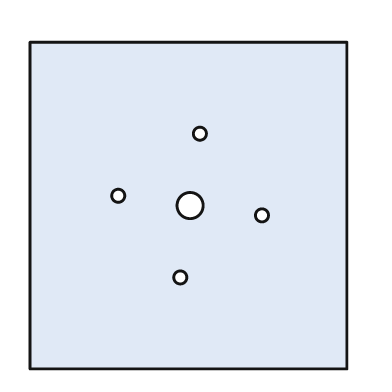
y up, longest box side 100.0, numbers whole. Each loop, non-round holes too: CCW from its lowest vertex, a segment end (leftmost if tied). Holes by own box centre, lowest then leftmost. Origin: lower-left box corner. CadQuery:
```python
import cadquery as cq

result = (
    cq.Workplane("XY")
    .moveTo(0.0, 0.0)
    .lineTo(97.0, 0.0)
    .lineTo(97.0, 100.0)
    .lineTo(0.0, 100.0)
    .close()
    .moveTo(46.0, 28.0)
    .circle(2.0)
    .moveTo(71.0, 47.0)
    .circle(2.0)
    .moveTo(49.0, 50.0)
    .circle(4.0)
    .moveTo(27.0, 53.0)
    .circle(2.0)
    .moveTo(52.0, 72.0)
    .circle(2.0)
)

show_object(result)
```